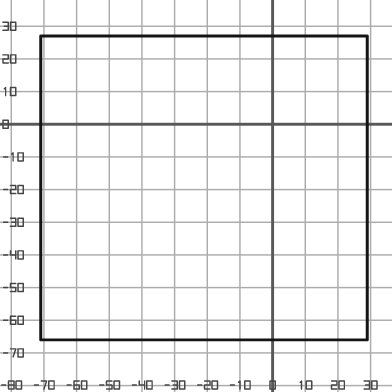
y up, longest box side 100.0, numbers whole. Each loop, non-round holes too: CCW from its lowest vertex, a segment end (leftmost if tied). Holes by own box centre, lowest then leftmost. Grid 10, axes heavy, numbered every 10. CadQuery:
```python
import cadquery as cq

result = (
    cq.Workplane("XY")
    .moveTo(-71.0, -66.0)
    .lineTo(29.0, -66.0)
    .lineTo(29.0, 27.0)
    .lineTo(-71.0, 27.0)
    .close()
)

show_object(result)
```